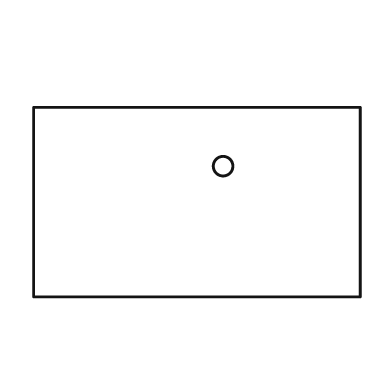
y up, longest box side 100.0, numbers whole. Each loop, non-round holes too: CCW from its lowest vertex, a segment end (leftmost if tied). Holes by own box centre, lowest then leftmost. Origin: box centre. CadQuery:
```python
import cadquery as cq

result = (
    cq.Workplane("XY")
    .moveTo(-50.0, -29.0)
    .lineTo(50.0, -29.0)
    .lineTo(50.0, 29.0)
    .lineTo(-50.0, 29.0)
    .close()
    .moveTo(8.0, 11.0)
    .circle(3.0)
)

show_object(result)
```